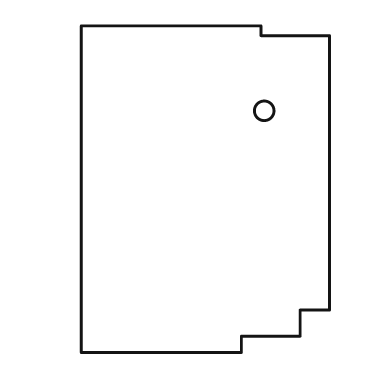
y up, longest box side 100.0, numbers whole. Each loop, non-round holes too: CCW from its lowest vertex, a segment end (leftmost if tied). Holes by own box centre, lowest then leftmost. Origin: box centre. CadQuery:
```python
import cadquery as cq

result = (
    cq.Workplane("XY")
    .moveTo(-38.0, -50.0)
    .lineTo(11.0, -50.0)
    .lineTo(11.0, -45.0)
    .lineTo(29.0, -45.0)
    .lineTo(29.0, -37.0)
    .lineTo(38.0, -37.0)
    .lineTo(38.0, 47.0)
    .lineTo(17.0, 47.0)
    .lineTo(17.0, 50.0)
    .lineTo(-38.0, 50.0)
    .close()
    .moveTo(18.0, 24.0)
    .circle(3.0)
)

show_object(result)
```